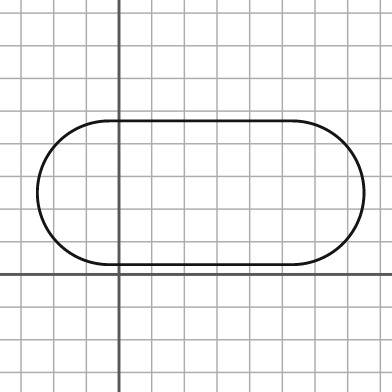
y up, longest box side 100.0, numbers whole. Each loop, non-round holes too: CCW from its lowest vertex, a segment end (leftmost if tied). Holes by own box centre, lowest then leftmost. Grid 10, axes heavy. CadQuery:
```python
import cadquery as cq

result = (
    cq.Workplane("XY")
    .moveTo(-3.0, 3.0)
    .lineTo(53.0, 3.0)
    .threePointArc((75.0, 25.0), (53.0, 47.0))
    .lineTo(-3.0, 47.0)
    .threePointArc((-25.0, 25.0), (-3.0, 3.0))
    .close()
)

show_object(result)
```